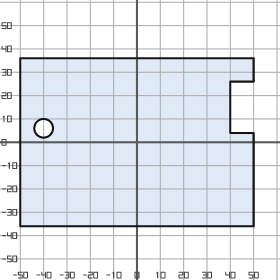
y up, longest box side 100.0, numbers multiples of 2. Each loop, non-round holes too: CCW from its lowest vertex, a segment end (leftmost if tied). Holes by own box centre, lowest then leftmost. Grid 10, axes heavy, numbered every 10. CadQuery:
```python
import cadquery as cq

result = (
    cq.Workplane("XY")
    .moveTo(-50.0, -36.0)
    .lineTo(50.0, -36.0)
    .lineTo(50.0, 4.0)
    .lineTo(40.0, 4.0)
    .lineTo(40.0, 26.0)
    .lineTo(50.0, 26.0)
    .lineTo(50.0, 36.0)
    .lineTo(-50.0, 36.0)
    .close()
    .moveTo(-40.0, 6.0)
    .circle(4.0)
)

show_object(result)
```